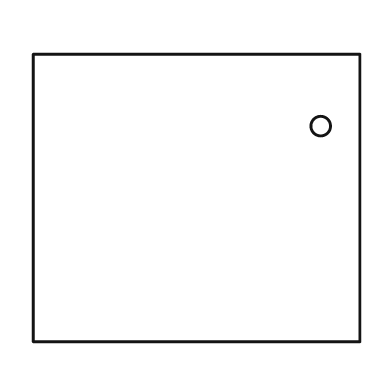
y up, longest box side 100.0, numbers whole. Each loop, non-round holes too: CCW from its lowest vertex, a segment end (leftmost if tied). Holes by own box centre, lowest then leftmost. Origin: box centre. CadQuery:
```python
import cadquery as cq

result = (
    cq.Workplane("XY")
    .moveTo(-50.0, -44.0)
    .lineTo(50.0, -44.0)
    .lineTo(50.0, 44.0)
    .lineTo(-50.0, 44.0)
    .close()
    .moveTo(38.0, 22.0)
    .circle(3.0)
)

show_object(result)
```